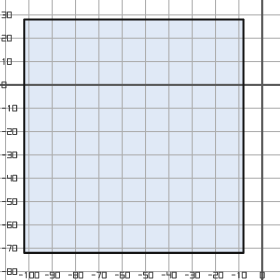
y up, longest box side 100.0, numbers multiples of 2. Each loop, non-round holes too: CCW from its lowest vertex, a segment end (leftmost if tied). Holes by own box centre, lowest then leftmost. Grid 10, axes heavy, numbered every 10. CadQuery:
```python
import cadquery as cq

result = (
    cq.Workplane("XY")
    .moveTo(-102.0, -72.0)
    .lineTo(-8.0, -72.0)
    .lineTo(-8.0, 28.0)
    .lineTo(-102.0, 28.0)
    .close()
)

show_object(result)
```